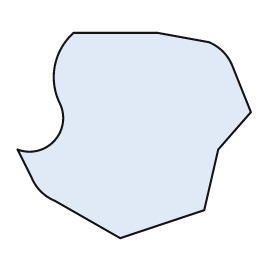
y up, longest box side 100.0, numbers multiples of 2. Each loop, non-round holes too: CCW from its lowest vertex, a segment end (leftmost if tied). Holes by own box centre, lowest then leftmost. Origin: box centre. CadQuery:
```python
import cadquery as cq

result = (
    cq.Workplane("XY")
    .moveTo(-6.0, -44.0)
    .lineTo(30.0, -32.0)
    .lineTo(36.0, -6.0)
    .lineTo(50.0, 10.0)
    .lineTo(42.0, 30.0)
    .threePointArc((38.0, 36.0), (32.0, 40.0))
    .lineTo(10.0, 44.0)
    .lineTo(-26.0, 44.0)
    .threePointArc((-34.0, 30.0), (-32.0, 14.0))
    .threePointArc((-34.0, -2.0), (-50.0, -6.0))
    .lineTo(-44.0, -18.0)
    .threePointArc((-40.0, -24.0), (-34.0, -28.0))
    .close()
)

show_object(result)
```